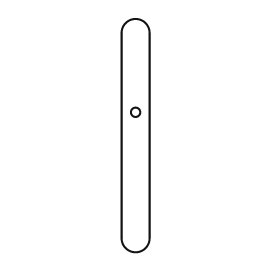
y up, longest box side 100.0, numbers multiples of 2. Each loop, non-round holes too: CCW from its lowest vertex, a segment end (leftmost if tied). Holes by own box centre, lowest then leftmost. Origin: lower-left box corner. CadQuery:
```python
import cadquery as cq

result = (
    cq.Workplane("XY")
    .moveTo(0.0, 6.0)
    .threePointArc((6.0, 0.0), (12.0, 6.0))
    .lineTo(12.0, 94.0)
    .threePointArc((6.0, 100.0), (0.0, 94.0))
    .close()
    .moveTo(6.0, 60.0)
    .circle(2.0)
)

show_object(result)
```